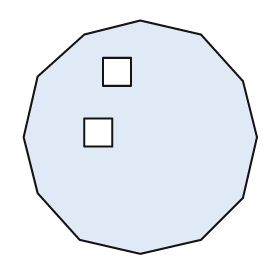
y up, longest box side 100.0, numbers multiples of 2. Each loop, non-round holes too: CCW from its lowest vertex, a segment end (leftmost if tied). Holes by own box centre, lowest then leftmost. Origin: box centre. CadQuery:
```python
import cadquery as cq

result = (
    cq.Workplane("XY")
    .moveTo(0.0, -50.0)
    .lineTo(26.0, -44.0)
    .lineTo(44.0, -26.0)
    .lineTo(50.0, 0.0)
    .lineTo(44.0, 24.0)
    .lineTo(26.0, 44.0)
    .lineTo(0.0, 50.0)
    .lineTo(-24.0, 44.0)
    .lineTo(-44.0, 26.0)
    .lineTo(-50.0, 0.0)
    .lineTo(-44.0, -24.0)
    .lineTo(-26.0, -44.0)
    .close()
    .moveTo(-24.0, -4.0)
    .lineTo(-12.0, -4.0)
    .lineTo(-12.0, 8.0)
    .lineTo(-24.0, 8.0)
    .close()
    .moveTo(-16.0, 22.0)
    .lineTo(-4.0, 22.0)
    .lineTo(-4.0, 34.0)
    .lineTo(-16.0, 34.0)
    .close()
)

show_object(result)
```